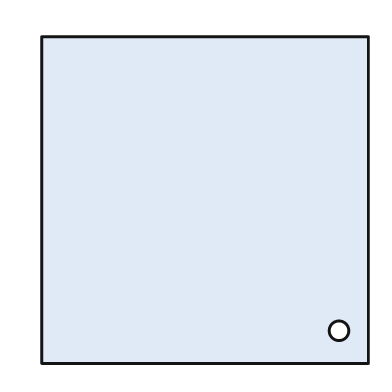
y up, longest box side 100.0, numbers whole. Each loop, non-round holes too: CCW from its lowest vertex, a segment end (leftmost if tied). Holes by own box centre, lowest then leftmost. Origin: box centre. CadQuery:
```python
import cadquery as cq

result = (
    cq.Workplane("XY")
    .moveTo(-50.0, -50.0)
    .lineTo(50.0, -50.0)
    .lineTo(50.0, 50.0)
    .lineTo(-50.0, 50.0)
    .close()
    .moveTo(41.0, -40.0)
    .circle(3.0)
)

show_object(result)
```